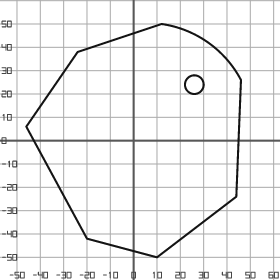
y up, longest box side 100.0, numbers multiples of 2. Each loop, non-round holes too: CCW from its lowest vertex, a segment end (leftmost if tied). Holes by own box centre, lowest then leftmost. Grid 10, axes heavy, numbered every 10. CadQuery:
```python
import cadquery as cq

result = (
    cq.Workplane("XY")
    .moveTo(10.0, -50.0)
    .lineTo(44.0, -24.0)
    .lineTo(46.0, 26.0)
    .threePointArc((32.0, 42.0), (12.0, 50.0))
    .lineTo(-24.0, 38.0)
    .lineTo(-46.0, 6.0)
    .lineTo(-20.0, -42.0)
    .close()
    .moveTo(26.0, 24.0)
    .circle(4.0)
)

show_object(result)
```